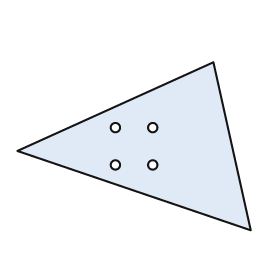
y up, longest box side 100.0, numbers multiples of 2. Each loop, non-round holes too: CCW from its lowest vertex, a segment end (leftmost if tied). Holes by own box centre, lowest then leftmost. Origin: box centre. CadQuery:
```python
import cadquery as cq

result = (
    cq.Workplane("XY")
    .moveTo(50.0, -36.0)
    .lineTo(34.0, 36.0)
    .lineTo(-50.0, -2.0)
    .close()
    .moveTo(-8.0, -8.0)
    .circle(2.0)
    .moveTo(8.0, -8.0)
    .circle(2.0)
    .moveTo(-8.0, 8.0)
    .circle(2.0)
    .moveTo(8.0, 8.0)
    .circle(2.0)
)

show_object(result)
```